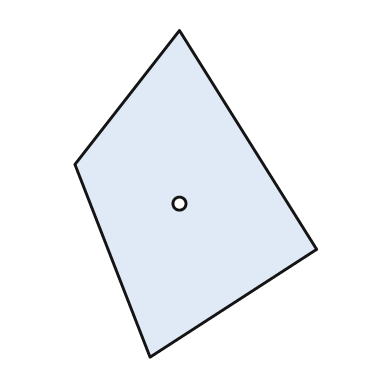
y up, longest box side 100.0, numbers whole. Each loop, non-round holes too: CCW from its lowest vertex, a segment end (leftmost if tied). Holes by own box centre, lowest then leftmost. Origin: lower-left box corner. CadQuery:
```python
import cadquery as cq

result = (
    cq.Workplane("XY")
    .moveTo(23.0, 0.0)
    .lineTo(74.0, 33.0)
    .lineTo(32.0, 100.0)
    .lineTo(0.0, 59.0)
    .close()
    .moveTo(32.0, 47.0)
    .circle(2.0)
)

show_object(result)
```